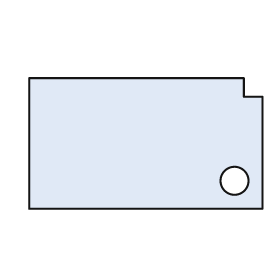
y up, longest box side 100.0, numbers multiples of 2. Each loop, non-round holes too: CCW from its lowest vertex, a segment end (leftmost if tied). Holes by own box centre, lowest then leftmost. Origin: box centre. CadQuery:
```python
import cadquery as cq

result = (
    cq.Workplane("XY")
    .moveTo(-50.0, -28.0)
    .lineTo(50.0, -28.0)
    .lineTo(50.0, 20.0)
    .lineTo(42.0, 20.0)
    .lineTo(42.0, 28.0)
    .lineTo(-50.0, 28.0)
    .close()
    .moveTo(38.0, -16.0)
    .circle(6.0)
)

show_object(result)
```